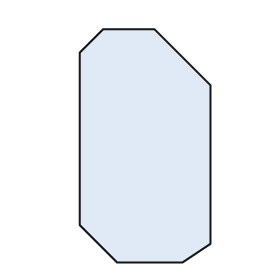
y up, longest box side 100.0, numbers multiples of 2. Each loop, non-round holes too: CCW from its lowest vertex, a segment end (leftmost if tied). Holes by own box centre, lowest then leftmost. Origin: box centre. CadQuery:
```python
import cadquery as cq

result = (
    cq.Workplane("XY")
    .moveTo(-12.0, -50.0)
    .lineTo(16.0, -50.0)
    .lineTo(28.0, -42.0)
    .lineTo(28.0, 26.0)
    .lineTo(4.0, 50.0)
    .lineTo(-18.0, 50.0)
    .lineTo(-28.0, 40.0)
    .lineTo(-28.0, -34.0)
    .close()
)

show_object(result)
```